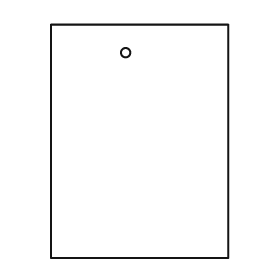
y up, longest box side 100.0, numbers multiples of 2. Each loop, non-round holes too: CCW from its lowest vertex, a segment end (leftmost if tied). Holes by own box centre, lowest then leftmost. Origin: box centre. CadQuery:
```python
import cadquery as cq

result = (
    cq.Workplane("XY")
    .moveTo(-38.0, -50.0)
    .lineTo(38.0, -50.0)
    .lineTo(38.0, 50.0)
    .lineTo(-38.0, 50.0)
    .close()
    .moveTo(-6.0, 38.0)
    .circle(2.0)
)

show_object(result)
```